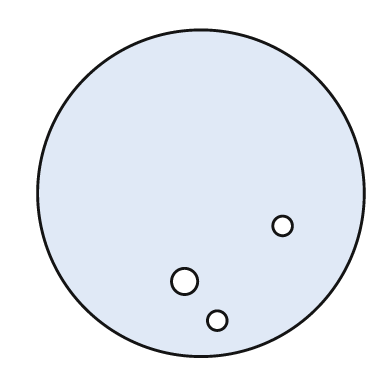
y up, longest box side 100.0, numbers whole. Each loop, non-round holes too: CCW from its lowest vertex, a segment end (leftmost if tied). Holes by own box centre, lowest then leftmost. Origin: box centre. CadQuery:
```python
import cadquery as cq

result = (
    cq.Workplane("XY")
    .moveTo(0.0, 0.0)
    .circle(50.0)
    .moveTo(5.0, -39.0)
    .circle(3.0)
    .moveTo(-5.0, -27.0)
    .circle(4.0)
    .moveTo(25.0, -10.0)
    .circle(3.0)
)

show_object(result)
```